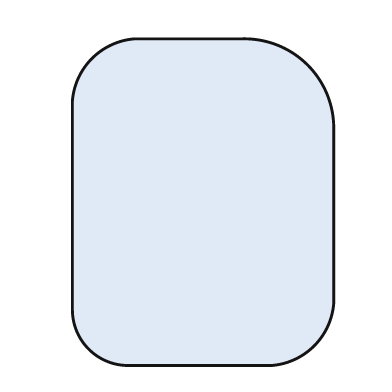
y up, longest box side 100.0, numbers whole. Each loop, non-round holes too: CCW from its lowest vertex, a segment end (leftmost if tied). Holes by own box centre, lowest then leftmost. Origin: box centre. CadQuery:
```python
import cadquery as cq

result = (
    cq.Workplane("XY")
    .moveTo(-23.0, -50.0)
    .lineTo(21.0, -50.0)
    .threePointArc((34.0, -44.0), (40.0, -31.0))
    .lineTo(40.0, 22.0)
    .threePointArc((32.0, 42.0), (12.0, 50.0))
    .lineTo(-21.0, 50.0)
    .threePointArc((-34.0, 44.0), (-40.0, 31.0))
    .lineTo(-40.0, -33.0)
    .threePointArc((-35.0, -45.0), (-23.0, -50.0))
    .close()
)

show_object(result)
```